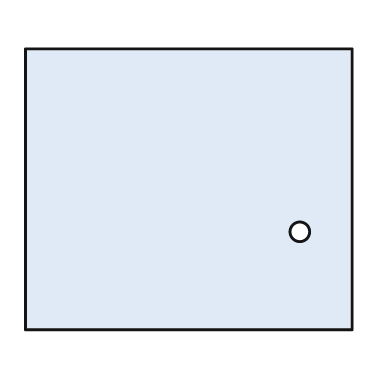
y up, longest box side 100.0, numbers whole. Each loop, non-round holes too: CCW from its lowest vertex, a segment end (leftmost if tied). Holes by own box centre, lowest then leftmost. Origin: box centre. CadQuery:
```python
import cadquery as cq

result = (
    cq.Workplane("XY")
    .moveTo(-50.0, -43.0)
    .lineTo(50.0, -43.0)
    .lineTo(50.0, 43.0)
    .lineTo(-50.0, 43.0)
    .close()
    .moveTo(34.0, -13.0)
    .circle(3.0)
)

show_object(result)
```